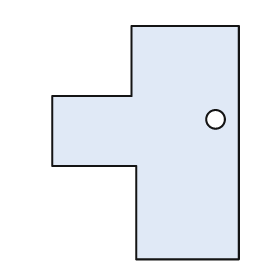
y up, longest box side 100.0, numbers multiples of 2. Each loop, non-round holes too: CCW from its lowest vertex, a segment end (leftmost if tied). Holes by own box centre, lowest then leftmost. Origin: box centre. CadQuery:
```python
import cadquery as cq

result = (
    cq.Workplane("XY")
    .moveTo(-4.0, -50.0)
    .lineTo(40.0, -50.0)
    .lineTo(40.0, 50.0)
    .lineTo(-6.0, 50.0)
    .lineTo(-6.0, 20.0)
    .lineTo(-40.0, 20.0)
    .lineTo(-40.0, -10.0)
    .lineTo(-4.0, -10.0)
    .close()
    .moveTo(30.0, 10.0)
    .circle(4.0)
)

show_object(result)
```